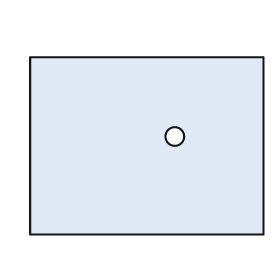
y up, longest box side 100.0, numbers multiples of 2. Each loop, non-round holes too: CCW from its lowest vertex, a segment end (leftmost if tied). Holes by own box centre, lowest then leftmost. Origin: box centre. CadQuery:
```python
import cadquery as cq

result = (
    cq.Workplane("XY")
    .moveTo(-50.0, -38.0)
    .lineTo(50.0, -38.0)
    .lineTo(50.0, 38.0)
    .lineTo(-50.0, 38.0)
    .close()
    .moveTo(12.0, 4.0)
    .circle(4.0)
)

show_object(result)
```